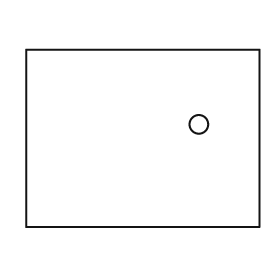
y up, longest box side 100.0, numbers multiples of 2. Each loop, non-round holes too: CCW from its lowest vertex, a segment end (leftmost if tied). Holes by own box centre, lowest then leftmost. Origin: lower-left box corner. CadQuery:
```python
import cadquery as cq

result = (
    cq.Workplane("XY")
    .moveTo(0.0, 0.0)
    .lineTo(100.0, 0.0)
    .lineTo(100.0, 76.0)
    .lineTo(0.0, 76.0)
    .close()
    .moveTo(74.0, 44.0)
    .circle(4.0)
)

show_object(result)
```